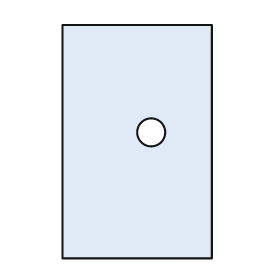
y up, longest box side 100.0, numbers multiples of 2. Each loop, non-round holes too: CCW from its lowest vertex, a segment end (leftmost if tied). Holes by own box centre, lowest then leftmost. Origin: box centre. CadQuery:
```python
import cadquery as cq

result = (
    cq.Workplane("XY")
    .moveTo(-32.0, -50.0)
    .lineTo(32.0, -50.0)
    .lineTo(32.0, 50.0)
    .lineTo(-32.0, 50.0)
    .close()
    .moveTo(6.0, 4.0)
    .circle(6.0)
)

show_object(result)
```